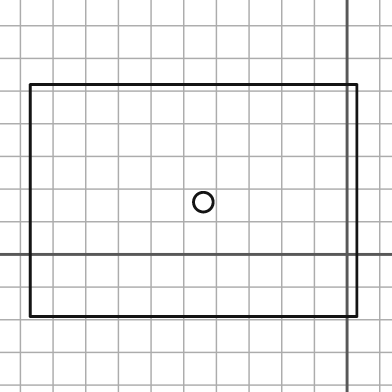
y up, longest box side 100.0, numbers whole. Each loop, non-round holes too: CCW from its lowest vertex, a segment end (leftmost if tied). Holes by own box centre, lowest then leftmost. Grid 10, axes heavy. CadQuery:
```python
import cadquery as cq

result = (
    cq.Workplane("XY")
    .moveTo(-97.0, -19.0)
    .lineTo(3.0, -19.0)
    .lineTo(3.0, 52.0)
    .lineTo(-97.0, 52.0)
    .close()
    .moveTo(-44.0, 16.0)
    .circle(3.0)
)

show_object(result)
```